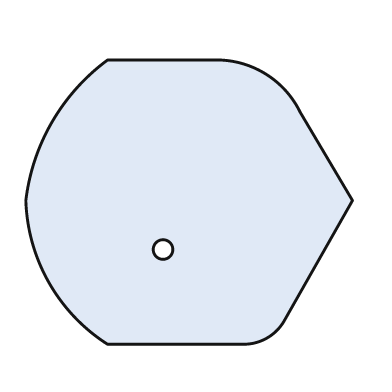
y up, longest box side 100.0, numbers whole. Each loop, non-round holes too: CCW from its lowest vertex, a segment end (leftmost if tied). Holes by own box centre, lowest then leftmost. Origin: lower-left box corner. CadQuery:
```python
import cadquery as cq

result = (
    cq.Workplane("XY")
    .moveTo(25.0, 0.0)
    .lineTo(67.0, 0.0)
    .threePointArc((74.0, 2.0), (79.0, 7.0))
    .lineTo(100.0, 44.0)
    .lineTo(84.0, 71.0)
    .threePointArc((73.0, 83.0), (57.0, 87.0))
    .lineTo(25.0, 87.0)
    .threePointArc((8.0, 68.0), (0.0, 44.0))
    .threePointArc((7.0, 19.0), (25.0, 0.0))
    .close()
    .moveTo(42.0, 29.0)
    .circle(3.0)
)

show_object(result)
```